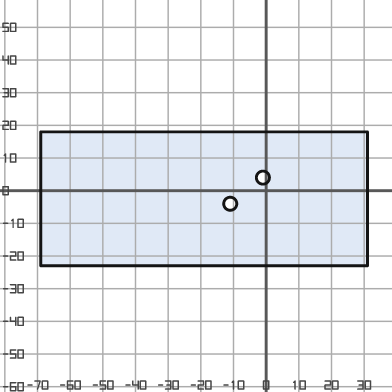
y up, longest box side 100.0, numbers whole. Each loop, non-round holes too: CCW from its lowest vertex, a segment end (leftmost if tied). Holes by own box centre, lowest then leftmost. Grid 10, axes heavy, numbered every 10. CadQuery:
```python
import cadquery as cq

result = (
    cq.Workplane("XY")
    .moveTo(-69.0, -23.0)
    .lineTo(31.0, -23.0)
    .lineTo(31.0, 18.0)
    .lineTo(-69.0, 18.0)
    .close()
    .moveTo(-11.0, -4.0)
    .circle(2.0)
    .moveTo(-1.0, 4.0)
    .circle(2.0)
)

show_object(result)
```